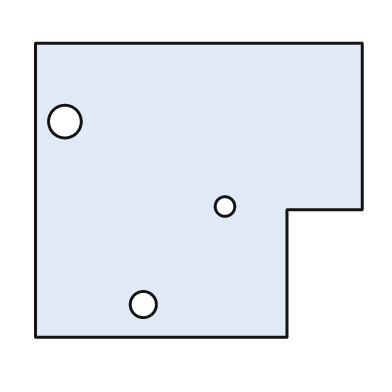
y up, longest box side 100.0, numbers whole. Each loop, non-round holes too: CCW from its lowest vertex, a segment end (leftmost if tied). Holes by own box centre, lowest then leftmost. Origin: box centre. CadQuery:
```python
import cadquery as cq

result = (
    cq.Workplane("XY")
    .moveTo(-50.0, -45.0)
    .lineTo(27.0, -45.0)
    .lineTo(27.0, -6.0)
    .lineTo(50.0, -6.0)
    .lineTo(50.0, 45.0)
    .lineTo(-50.0, 45.0)
    .close()
    .moveTo(-17.0, -35.0)
    .circle(4.0)
    .moveTo(8.0, -5.0)
    .circle(3.0)
    .moveTo(-41.0, 21.0)
    .circle(5.0)
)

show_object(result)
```